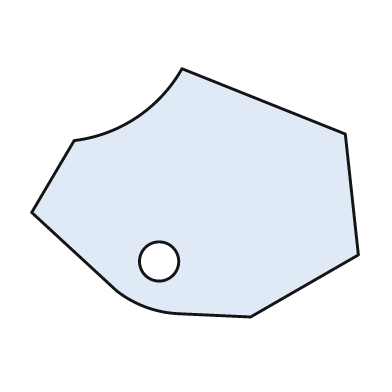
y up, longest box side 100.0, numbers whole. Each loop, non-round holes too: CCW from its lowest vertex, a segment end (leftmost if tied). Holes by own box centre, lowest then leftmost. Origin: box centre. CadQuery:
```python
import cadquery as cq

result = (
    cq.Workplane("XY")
    .moveTo(17.0, -38.0)
    .lineTo(50.0, -19.0)
    .lineTo(46.0, 18.0)
    .lineTo(-4.0, 38.0)
    .threePointArc((-18.0, 23.0), (-37.0, 16.0))
    .lineTo(-50.0, -6.0)
    .lineTo(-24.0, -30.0)
    .threePointArc((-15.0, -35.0), (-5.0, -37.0))
    .close()
    .moveTo(-11.0, -21.0)
    .circle(6.0)
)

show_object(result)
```